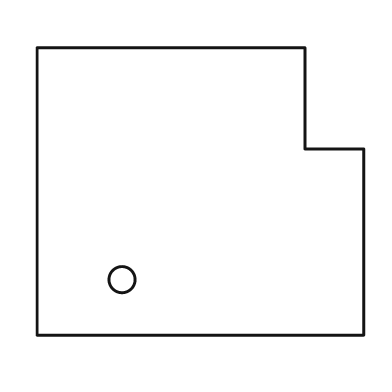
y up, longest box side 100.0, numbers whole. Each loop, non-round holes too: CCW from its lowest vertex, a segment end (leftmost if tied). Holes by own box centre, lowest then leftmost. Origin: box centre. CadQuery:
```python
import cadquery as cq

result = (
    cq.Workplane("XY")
    .moveTo(-50.0, -44.0)
    .lineTo(50.0, -44.0)
    .lineTo(50.0, 13.0)
    .lineTo(32.0, 13.0)
    .lineTo(32.0, 44.0)
    .lineTo(-50.0, 44.0)
    .close()
    .moveTo(-24.0, -27.0)
    .circle(4.0)
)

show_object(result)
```